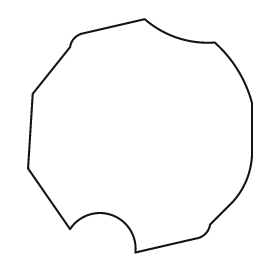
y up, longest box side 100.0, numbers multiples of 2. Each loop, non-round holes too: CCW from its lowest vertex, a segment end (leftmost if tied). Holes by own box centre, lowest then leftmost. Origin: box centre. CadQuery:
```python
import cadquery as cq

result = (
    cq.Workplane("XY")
    .moveTo(-2.0, -50.0)
    .lineTo(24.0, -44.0)
    .threePointArc((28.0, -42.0), (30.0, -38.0))
    .lineTo(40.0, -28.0)
    .threePointArc((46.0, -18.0), (48.0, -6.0))
    .lineTo(48.0, 14.0)
    .threePointArc((42.0, 28.0), (32.0, 40.0))
    .threePointArc((16.0, 42.0), (2.0, 50.0))
    .lineTo(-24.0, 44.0)
    .threePointArc((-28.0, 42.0), (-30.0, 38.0))
    .lineTo(-46.0, 18.0)
    .lineTo(-48.0, -14.0)
    .lineTo(-30.0, -40.0)
    .threePointArc((-12.0, -34.0), (-2.0, -50.0))
    .close()
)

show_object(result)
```